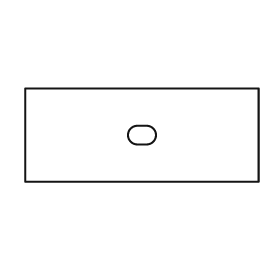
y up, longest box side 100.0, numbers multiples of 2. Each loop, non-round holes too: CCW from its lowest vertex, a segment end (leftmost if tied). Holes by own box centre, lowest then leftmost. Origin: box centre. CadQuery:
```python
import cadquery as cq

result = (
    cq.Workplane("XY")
    .moveTo(-50.0, -20.0)
    .lineTo(50.0, -20.0)
    .lineTo(50.0, 20.0)
    .lineTo(-50.0, 20.0)
    .close()
    .moveTo(-2.0, -4.0)
    .lineTo(2.0, -4.0)
    .threePointArc((6.0, 0.0), (2.0, 4.0))
    .lineTo(-2.0, 4.0)
    .threePointArc((-6.0, 0.0), (-2.0, -4.0))
    .close()
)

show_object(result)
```